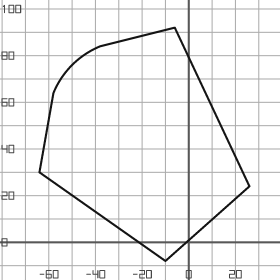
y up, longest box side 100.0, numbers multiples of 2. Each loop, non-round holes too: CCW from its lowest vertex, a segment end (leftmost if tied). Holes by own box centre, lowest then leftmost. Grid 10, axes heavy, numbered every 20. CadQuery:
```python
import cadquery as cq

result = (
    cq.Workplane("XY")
    .moveTo(-10.0, -8.0)
    .lineTo(26.0, 24.0)
    .lineTo(-6.0, 92.0)
    .lineTo(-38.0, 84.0)
    .threePointArc((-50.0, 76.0), (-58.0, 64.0))
    .lineTo(-64.0, 30.0)
    .close()
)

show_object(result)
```